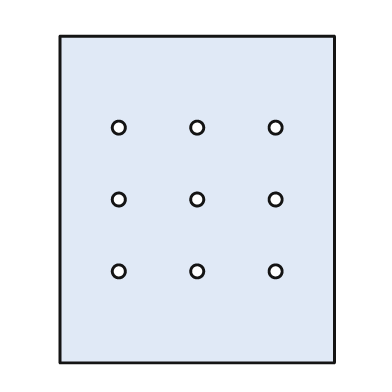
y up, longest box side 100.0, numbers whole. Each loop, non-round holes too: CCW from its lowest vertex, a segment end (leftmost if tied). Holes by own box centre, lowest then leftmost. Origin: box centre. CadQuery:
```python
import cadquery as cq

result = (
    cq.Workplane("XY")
    .moveTo(-42.0, -50.0)
    .lineTo(42.0, -50.0)
    .lineTo(42.0, 50.0)
    .lineTo(-42.0, 50.0)
    .close()
    .moveTo(-24.0, -22.0)
    .circle(2.0)
    .moveTo(0.0, -22.0)
    .circle(2.0)
    .moveTo(24.0, -22.0)
    .circle(2.0)
    .moveTo(-24.0, 0.0)
    .circle(2.0)
    .moveTo(0.0, 0.0)
    .circle(2.0)
    .moveTo(24.0, 0.0)
    .circle(2.0)
    .moveTo(-24.0, 22.0)
    .circle(2.0)
    .moveTo(0.0, 22.0)
    .circle(2.0)
    .moveTo(24.0, 22.0)
    .circle(2.0)
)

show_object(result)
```